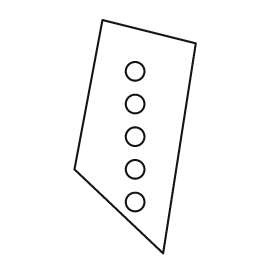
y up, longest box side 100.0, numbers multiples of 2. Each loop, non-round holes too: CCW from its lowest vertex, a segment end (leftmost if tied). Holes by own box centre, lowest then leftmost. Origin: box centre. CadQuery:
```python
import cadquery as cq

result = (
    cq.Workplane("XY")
    .moveTo(12.0, -50.0)
    .lineTo(26.0, 40.0)
    .lineTo(-14.0, 50.0)
    .lineTo(-26.0, -14.0)
    .close()
    .moveTo(0.0, -28.0)
    .circle(4.0)
    .moveTo(0.0, -14.0)
    .circle(4.0)
    .moveTo(0.0, 0.0)
    .circle(4.0)
    .moveTo(0.0, 14.0)
    .circle(4.0)
    .moveTo(0.0, 28.0)
    .circle(4.0)
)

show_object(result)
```